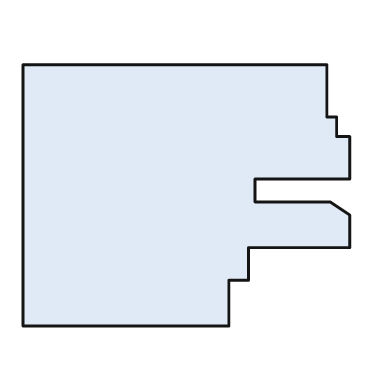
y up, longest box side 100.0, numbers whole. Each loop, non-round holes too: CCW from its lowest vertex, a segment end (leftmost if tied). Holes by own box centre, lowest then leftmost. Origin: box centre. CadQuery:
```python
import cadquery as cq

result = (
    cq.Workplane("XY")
    .moveTo(-50.0, -40.0)
    .lineTo(13.0, -40.0)
    .lineTo(13.0, -26.0)
    .lineTo(19.0, -26.0)
    .lineTo(19.0, -16.0)
    .lineTo(50.0, -16.0)
    .lineTo(50.0, -6.0)
    .lineTo(44.0, -2.0)
    .lineTo(21.0, -2.0)
    .lineTo(21.0, 5.0)
    .lineTo(50.0, 5.0)
    .lineTo(50.0, 18.0)
    .lineTo(46.0, 18.0)
    .lineTo(46.0, 24.0)
    .lineTo(43.0, 24.0)
    .lineTo(43.0, 40.0)
    .lineTo(-50.0, 40.0)
    .close()
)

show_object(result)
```